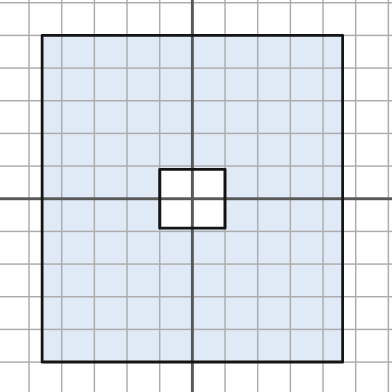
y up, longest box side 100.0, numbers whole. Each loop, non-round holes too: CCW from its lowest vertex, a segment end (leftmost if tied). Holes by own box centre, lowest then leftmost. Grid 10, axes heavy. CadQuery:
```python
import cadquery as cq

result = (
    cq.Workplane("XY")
    .moveTo(-46.0, -50.0)
    .lineTo(46.0, -50.0)
    .lineTo(46.0, 50.0)
    .lineTo(-46.0, 50.0)
    .close()
    .moveTo(-10.0, -9.0)
    .lineTo(10.0, -9.0)
    .lineTo(10.0, 9.0)
    .lineTo(-10.0, 9.0)
    .close()
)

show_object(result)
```